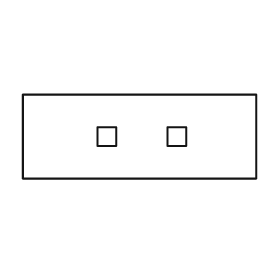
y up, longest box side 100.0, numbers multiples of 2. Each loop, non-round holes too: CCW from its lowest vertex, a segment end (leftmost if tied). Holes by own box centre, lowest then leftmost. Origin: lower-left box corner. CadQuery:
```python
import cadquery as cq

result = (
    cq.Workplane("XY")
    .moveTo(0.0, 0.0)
    .lineTo(100.0, 0.0)
    .lineTo(100.0, 36.0)
    .lineTo(0.0, 36.0)
    .close()
    .moveTo(32.0, 14.0)
    .lineTo(40.0, 14.0)
    .lineTo(40.0, 22.0)
    .lineTo(32.0, 22.0)
    .close()
    .moveTo(62.0, 14.0)
    .lineTo(70.0, 14.0)
    .lineTo(70.0, 22.0)
    .lineTo(62.0, 22.0)
    .close()
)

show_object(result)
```